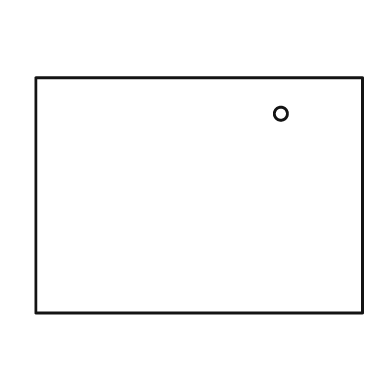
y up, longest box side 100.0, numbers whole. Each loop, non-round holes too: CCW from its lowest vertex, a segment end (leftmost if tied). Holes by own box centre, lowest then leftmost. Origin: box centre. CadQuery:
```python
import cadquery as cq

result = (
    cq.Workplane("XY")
    .moveTo(-50.0, -36.0)
    .lineTo(50.0, -36.0)
    .lineTo(50.0, 36.0)
    .lineTo(-50.0, 36.0)
    .close()
    .moveTo(25.0, 25.0)
    .circle(2.0)
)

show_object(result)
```